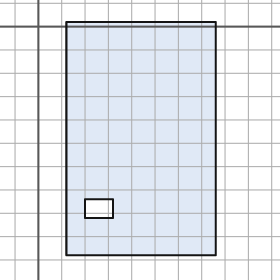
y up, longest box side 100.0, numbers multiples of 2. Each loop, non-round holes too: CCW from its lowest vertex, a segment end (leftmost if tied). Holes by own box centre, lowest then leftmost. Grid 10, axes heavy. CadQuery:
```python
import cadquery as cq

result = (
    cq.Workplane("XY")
    .moveTo(12.0, -98.0)
    .lineTo(76.0, -98.0)
    .lineTo(76.0, 2.0)
    .lineTo(12.0, 2.0)
    .close()
    .moveTo(20.0, -82.0)
    .lineTo(32.0, -82.0)
    .lineTo(32.0, -74.0)
    .lineTo(20.0, -74.0)
    .close()
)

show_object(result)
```